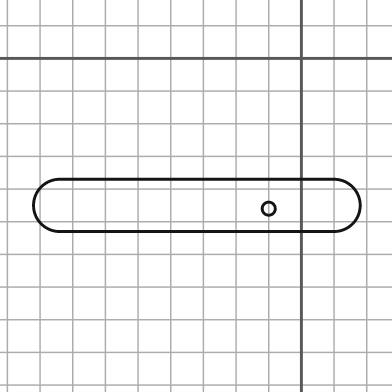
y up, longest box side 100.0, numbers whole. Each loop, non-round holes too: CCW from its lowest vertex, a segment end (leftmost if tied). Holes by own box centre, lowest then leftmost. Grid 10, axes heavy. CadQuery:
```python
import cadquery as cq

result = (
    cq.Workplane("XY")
    .moveTo(-74.0, -53.0)
    .lineTo(10.0, -53.0)
    .threePointArc((18.0, -45.0), (10.0, -37.0))
    .lineTo(-74.0, -37.0)
    .threePointArc((-82.0, -45.0), (-74.0, -53.0))
    .close()
    .moveTo(-10.0, -46.0)
    .circle(2.0)
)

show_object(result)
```